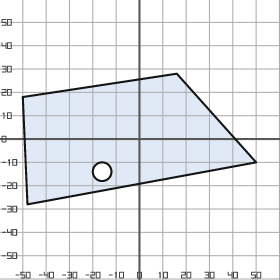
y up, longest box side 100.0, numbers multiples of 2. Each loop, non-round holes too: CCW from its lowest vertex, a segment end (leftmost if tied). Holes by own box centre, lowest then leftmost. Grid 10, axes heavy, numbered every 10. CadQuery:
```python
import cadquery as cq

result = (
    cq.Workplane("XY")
    .moveTo(-48.0, -28.0)
    .lineTo(50.0, -10.0)
    .lineTo(16.0, 28.0)
    .lineTo(-50.0, 18.0)
    .close()
    .moveTo(-16.0, -14.0)
    .circle(4.0)
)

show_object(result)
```